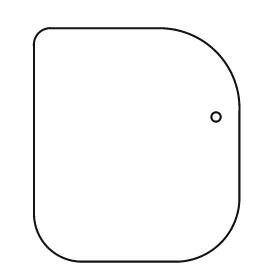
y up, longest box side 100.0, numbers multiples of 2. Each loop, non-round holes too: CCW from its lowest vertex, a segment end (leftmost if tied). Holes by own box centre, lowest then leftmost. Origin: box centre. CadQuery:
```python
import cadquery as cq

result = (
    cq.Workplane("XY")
    .moveTo(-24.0, -50.0)
    .lineTo(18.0, -50.0)
    .threePointArc((36.0, -42.0), (44.0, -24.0))
    .lineTo(44.0, 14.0)
    .threePointArc((34.0, 40.0), (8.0, 50.0))
    .lineTo(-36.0, 50.0)
    .threePointArc((-42.0, 48.0), (-44.0, 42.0))
    .lineTo(-44.0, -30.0)
    .threePointArc((-38.0, -44.0), (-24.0, -50.0))
    .close()
    .moveTo(34.0, 12.0)
    .circle(2.0)
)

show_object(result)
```